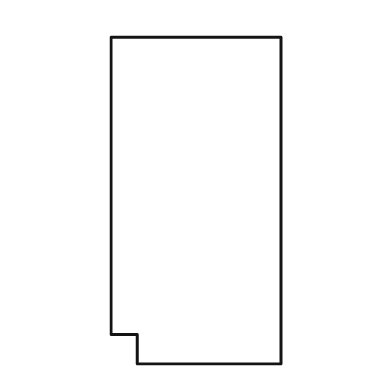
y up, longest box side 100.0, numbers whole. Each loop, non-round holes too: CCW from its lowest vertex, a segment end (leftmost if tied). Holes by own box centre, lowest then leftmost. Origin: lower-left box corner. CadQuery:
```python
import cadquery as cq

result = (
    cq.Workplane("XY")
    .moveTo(8.0, 0.0)
    .lineTo(52.0, 0.0)
    .lineTo(52.0, 100.0)
    .lineTo(0.0, 100.0)
    .lineTo(0.0, 9.0)
    .lineTo(8.0, 9.0)
    .close()
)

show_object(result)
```